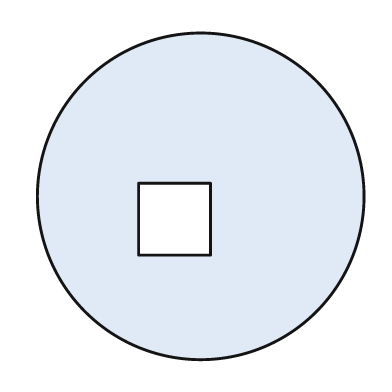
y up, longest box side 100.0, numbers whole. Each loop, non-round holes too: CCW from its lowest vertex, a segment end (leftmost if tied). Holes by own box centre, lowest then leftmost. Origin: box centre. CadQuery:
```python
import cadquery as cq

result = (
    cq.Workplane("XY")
    .moveTo(0.0, 0.0)
    .circle(50.0)
    .moveTo(-19.0, -18.0)
    .lineTo(3.0, -18.0)
    .lineTo(3.0, 4.0)
    .lineTo(-19.0, 4.0)
    .close()
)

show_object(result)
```